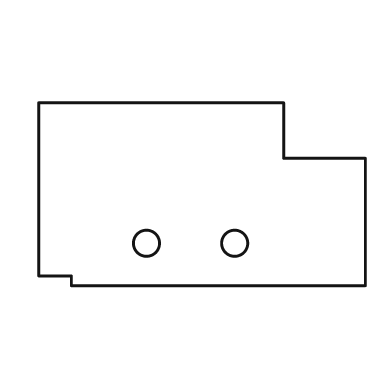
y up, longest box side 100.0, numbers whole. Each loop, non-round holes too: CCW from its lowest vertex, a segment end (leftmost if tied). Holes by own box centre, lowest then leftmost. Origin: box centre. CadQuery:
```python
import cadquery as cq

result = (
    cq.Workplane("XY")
    .moveTo(-40.0, -28.0)
    .lineTo(50.0, -28.0)
    .lineTo(50.0, 11.0)
    .lineTo(25.0, 11.0)
    .lineTo(25.0, 28.0)
    .lineTo(-50.0, 28.0)
    .lineTo(-50.0, -25.0)
    .lineTo(-40.0, -25.0)
    .close()
    .moveTo(-17.0, -15.0)
    .circle(4.0)
    .moveTo(10.0, -15.0)
    .circle(4.0)
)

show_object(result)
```